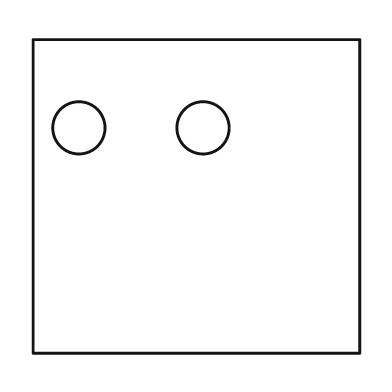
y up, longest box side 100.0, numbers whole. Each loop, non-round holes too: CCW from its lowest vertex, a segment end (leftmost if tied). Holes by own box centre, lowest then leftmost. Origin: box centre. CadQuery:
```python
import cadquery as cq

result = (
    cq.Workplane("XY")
    .moveTo(-50.0, -48.0)
    .lineTo(50.0, -48.0)
    .lineTo(50.0, 48.0)
    .lineTo(-50.0, 48.0)
    .close()
    .moveTo(-36.0, 21.0)
    .circle(8.0)
    .moveTo(2.0, 21.0)
    .circle(8.0)
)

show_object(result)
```